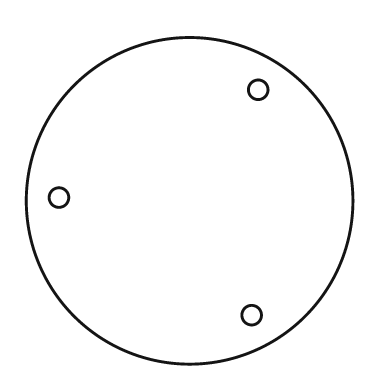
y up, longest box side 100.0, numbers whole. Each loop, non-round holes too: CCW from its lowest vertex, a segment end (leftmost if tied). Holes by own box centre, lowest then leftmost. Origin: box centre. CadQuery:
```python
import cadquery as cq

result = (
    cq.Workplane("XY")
    .moveTo(0.0, 0.0)
    .circle(50.0)
    .moveTo(19.0, -35.0)
    .circle(3.0)
    .moveTo(-40.0, 1.0)
    .circle(3.0)
    .moveTo(21.0, 34.0)
    .circle(3.0)
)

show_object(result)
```